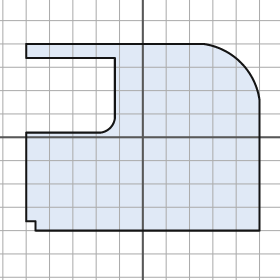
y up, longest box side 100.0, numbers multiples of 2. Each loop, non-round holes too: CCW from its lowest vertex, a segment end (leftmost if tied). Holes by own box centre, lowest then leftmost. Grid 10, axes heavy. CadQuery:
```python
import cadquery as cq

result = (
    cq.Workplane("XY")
    .moveTo(-46.0, -40.0)
    .lineTo(50.0, -40.0)
    .lineTo(50.0, 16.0)
    .threePointArc((42.0, 32.0), (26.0, 40.0))
    .lineTo(-50.0, 40.0)
    .lineTo(-50.0, 34.0)
    .lineTo(-12.0, 34.0)
    .lineTo(-12.0, 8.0)
    .threePointArc((-14.0, 4.0), (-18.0, 2.0))
    .lineTo(-50.0, 2.0)
    .lineTo(-50.0, -36.0)
    .lineTo(-46.0, -36.0)
    .close()
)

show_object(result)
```